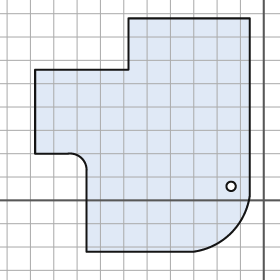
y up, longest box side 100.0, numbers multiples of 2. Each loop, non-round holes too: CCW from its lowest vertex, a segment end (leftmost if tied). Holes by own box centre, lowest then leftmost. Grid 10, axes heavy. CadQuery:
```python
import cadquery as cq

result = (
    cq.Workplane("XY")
    .moveTo(-76.0, -22.0)
    .lineTo(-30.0, -22.0)
    .threePointArc((-14.0, -14.0), (-6.0, 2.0))
    .lineTo(-6.0, 78.0)
    .lineTo(-58.0, 78.0)
    .lineTo(-58.0, 56.0)
    .lineTo(-98.0, 56.0)
    .lineTo(-98.0, 20.0)
    .lineTo(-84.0, 20.0)
    .threePointArc((-78.0, 18.0), (-76.0, 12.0))
    .close()
    .moveTo(-14.0, 6.0)
    .circle(2.0)
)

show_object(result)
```